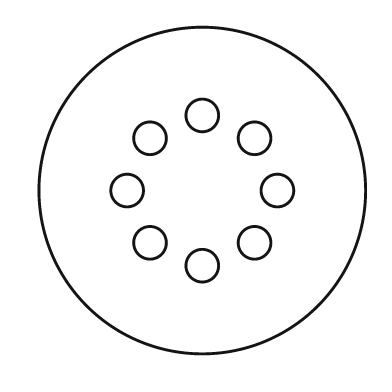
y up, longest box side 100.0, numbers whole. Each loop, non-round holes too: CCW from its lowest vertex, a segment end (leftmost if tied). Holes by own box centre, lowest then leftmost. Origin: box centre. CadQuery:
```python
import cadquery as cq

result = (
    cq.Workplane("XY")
    .moveTo(0.0, 0.0)
    .circle(50.0)
    .moveTo(0.0, -23.0)
    .circle(5.0)
    .moveTo(-16.0, -16.0)
    .circle(5.0)
    .moveTo(16.0, -16.0)
    .circle(5.0)
    .moveTo(-23.0, 0.0)
    .circle(5.0)
    .moveTo(23.0, 0.0)
    .circle(5.0)
    .moveTo(-16.0, 16.0)
    .circle(5.0)
    .moveTo(16.0, 16.0)
    .circle(5.0)
    .moveTo(0.0, 23.0)
    .circle(5.0)
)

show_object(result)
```